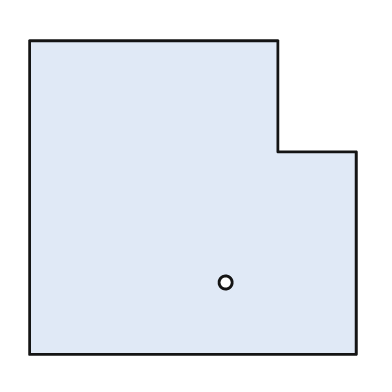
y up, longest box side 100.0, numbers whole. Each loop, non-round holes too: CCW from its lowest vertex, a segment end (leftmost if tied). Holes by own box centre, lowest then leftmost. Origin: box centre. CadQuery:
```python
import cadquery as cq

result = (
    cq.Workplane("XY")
    .moveTo(-50.0, -48.0)
    .lineTo(50.0, -48.0)
    .lineTo(50.0, 14.0)
    .lineTo(26.0, 14.0)
    .lineTo(26.0, 48.0)
    .lineTo(-50.0, 48.0)
    .close()
    .moveTo(10.0, -26.0)
    .circle(2.0)
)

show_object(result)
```